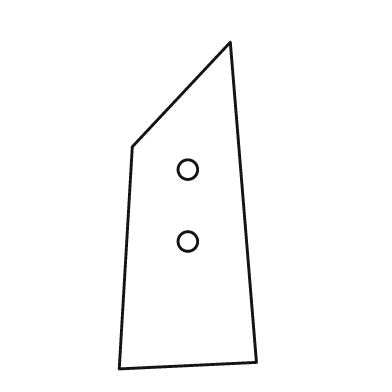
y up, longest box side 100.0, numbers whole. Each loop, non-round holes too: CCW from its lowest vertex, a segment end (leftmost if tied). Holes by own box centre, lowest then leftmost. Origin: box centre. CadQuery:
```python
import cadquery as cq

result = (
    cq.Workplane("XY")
    .moveTo(-21.0, -50.0)
    .lineTo(21.0, -48.0)
    .lineTo(13.0, 50.0)
    .lineTo(-17.0, 18.0)
    .close()
    .moveTo(0.0, -11.0)
    .circle(3.0)
    .moveTo(0.0, 11.0)
    .circle(3.0)
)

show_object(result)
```